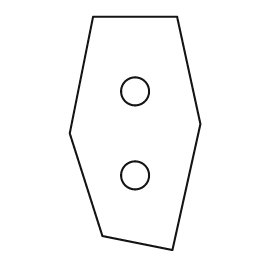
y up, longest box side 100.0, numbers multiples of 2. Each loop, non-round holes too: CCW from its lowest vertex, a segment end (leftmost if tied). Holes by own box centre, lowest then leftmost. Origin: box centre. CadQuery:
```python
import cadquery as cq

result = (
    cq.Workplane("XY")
    .moveTo(16.0, -50.0)
    .lineTo(28.0, 4.0)
    .lineTo(18.0, 50.0)
    .lineTo(-18.0, 50.0)
    .lineTo(-28.0, 0.0)
    .lineTo(-14.0, -44.0)
    .close()
    .moveTo(0.0, -18.0)
    .circle(6.0)
    .moveTo(0.0, 18.0)
    .circle(6.0)
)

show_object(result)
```